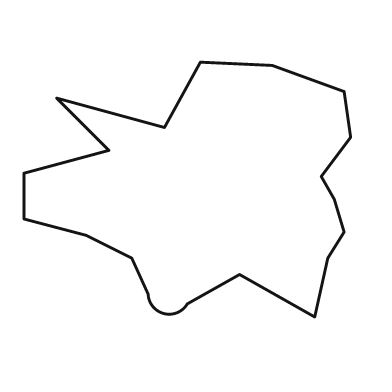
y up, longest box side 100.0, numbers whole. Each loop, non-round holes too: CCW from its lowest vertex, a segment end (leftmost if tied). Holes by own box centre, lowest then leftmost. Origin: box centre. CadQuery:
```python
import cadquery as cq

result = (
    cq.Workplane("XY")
    .moveTo(39.0, -39.0)
    .lineTo(43.0, -21.0)
    .lineTo(48.0, -13.0)
    .lineTo(45.0, -3.0)
    .lineTo(41.0, 4.0)
    .lineTo(50.0, 16.0)
    .lineTo(48.0, 30.0)
    .lineTo(26.0, 38.0)
    .lineTo(4.0, 39.0)
    .lineTo(-7.0, 19.0)
    .lineTo(-40.0, 28.0)
    .lineTo(-24.0, 12.0)
    .lineTo(-50.0, 5.0)
    .lineTo(-50.0, -9.0)
    .lineTo(-31.0, -14.0)
    .lineTo(-17.0, -21.0)
    .lineTo(-12.0, -32.0)
    .threePointArc((-7.0, -38.0), (0.0, -35.0))
    .lineTo(16.0, -26.0)
    .close()
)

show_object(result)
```